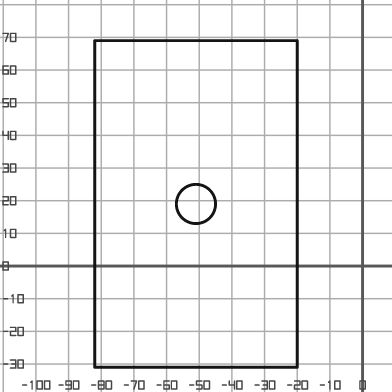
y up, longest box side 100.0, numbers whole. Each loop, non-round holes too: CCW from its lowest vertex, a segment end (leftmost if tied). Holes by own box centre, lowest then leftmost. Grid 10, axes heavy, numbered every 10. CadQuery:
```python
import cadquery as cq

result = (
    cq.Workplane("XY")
    .moveTo(-82.0, -31.0)
    .lineTo(-20.0, -31.0)
    .lineTo(-20.0, 69.0)
    .lineTo(-82.0, 69.0)
    .close()
    .moveTo(-51.0, 19.0)
    .circle(6.0)
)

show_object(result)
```